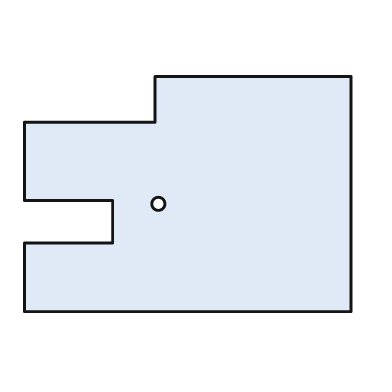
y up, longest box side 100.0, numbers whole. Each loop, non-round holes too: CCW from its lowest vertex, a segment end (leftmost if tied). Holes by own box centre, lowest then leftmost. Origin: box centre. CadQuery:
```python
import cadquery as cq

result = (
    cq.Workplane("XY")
    .moveTo(-50.0, -36.0)
    .lineTo(50.0, -36.0)
    .lineTo(50.0, 36.0)
    .lineTo(-10.0, 36.0)
    .lineTo(-10.0, 22.0)
    .lineTo(-50.0, 22.0)
    .lineTo(-50.0, -2.0)
    .lineTo(-23.0, -2.0)
    .lineTo(-23.0, -15.0)
    .lineTo(-50.0, -15.0)
    .close()
    .moveTo(-9.0, -3.0)
    .circle(2.0)
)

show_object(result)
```